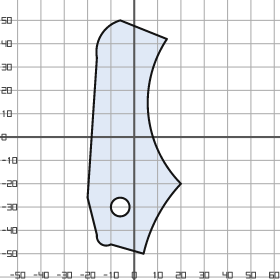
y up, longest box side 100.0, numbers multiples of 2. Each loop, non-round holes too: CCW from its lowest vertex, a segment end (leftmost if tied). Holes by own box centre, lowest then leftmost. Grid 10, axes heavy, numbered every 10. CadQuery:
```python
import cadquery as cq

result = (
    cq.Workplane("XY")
    .moveTo(4.0, -50.0)
    .threePointArc((10.0, -34.0), (20.0, -20.0))
    .threePointArc((6.0, 10.0), (14.0, 42.0))
    .lineTo(-6.0, 50.0)
    .threePointArc((-14.0, 44.0), (-16.0, 34.0))
    .lineTo(-20.0, -26.0)
    .lineTo(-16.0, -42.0)
    .threePointArc((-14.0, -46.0), (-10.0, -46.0))
    .close()
    .moveTo(-6.0, -30.0)
    .circle(4.0)
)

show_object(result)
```